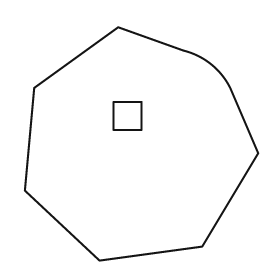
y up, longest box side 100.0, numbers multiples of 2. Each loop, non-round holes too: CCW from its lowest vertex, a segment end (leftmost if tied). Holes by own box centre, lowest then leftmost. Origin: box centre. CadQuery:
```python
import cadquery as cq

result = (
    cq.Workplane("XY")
    .moveTo(-18.0, -50.0)
    .lineTo(26.0, -44.0)
    .lineTo(50.0, -4.0)
    .lineTo(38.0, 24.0)
    .threePointArc((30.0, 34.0), (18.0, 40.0))
    .lineTo(-10.0, 50.0)
    .lineTo(-46.0, 24.0)
    .lineTo(-50.0, -20.0)
    .close()
    .moveTo(-12.0, 6.0)
    .lineTo(0.0, 6.0)
    .lineTo(0.0, 18.0)
    .lineTo(-12.0, 18.0)
    .close()
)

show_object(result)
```